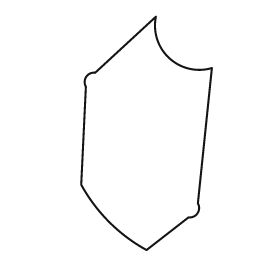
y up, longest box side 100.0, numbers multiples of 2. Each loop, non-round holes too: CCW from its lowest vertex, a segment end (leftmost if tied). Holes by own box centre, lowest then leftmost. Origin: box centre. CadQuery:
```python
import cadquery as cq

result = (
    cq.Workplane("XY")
    .moveTo(0.0, -50.0)
    .lineTo(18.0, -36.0)
    .threePointArc((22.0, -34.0), (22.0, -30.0))
    .lineTo(28.0, 28.0)
    .threePointArc((10.0, 32.0), (4.0, 50.0))
    .lineTo(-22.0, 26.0)
    .threePointArc((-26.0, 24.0), (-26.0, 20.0))
    .lineTo(-28.0, -22.0)
    .threePointArc((-16.0, -38.0), (0.0, -50.0))
    .close()
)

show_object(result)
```